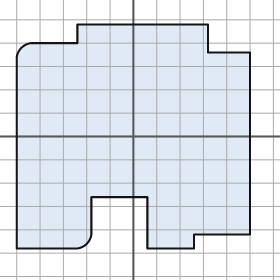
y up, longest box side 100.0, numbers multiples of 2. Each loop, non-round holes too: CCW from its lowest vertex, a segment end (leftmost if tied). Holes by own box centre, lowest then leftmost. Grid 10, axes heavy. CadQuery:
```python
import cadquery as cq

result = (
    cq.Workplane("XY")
    .moveTo(-50.0, -48.0)
    .lineTo(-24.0, -48.0)
    .threePointArc((-20.0, -46.0), (-18.0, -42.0))
    .lineTo(-18.0, -26.0)
    .lineTo(6.0, -26.0)
    .lineTo(6.0, -48.0)
    .lineTo(26.0, -48.0)
    .lineTo(26.0, -42.0)
    .lineTo(50.0, -42.0)
    .lineTo(50.0, 36.0)
    .lineTo(32.0, 36.0)
    .lineTo(32.0, 48.0)
    .lineTo(-24.0, 48.0)
    .lineTo(-24.0, 40.0)
    .lineTo(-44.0, 40.0)
    .threePointArc((-48.0, 38.0), (-50.0, 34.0))
    .close()
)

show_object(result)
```